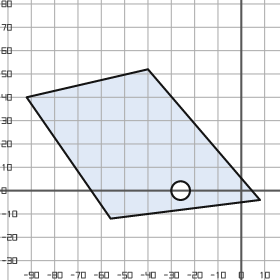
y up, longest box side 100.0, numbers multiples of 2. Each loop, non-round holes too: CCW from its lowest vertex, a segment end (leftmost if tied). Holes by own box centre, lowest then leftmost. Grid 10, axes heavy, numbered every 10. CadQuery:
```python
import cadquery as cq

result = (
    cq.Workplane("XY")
    .moveTo(-56.0, -12.0)
    .lineTo(8.0, -4.0)
    .lineTo(-40.0, 52.0)
    .lineTo(-92.0, 40.0)
    .close()
    .moveTo(-26.0, 0.0)
    .circle(4.0)
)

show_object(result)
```